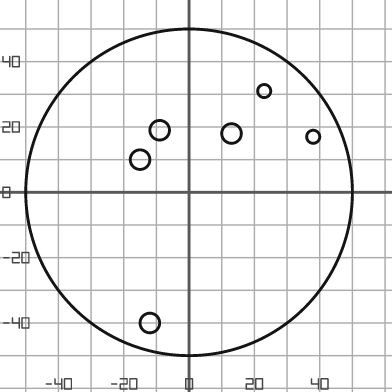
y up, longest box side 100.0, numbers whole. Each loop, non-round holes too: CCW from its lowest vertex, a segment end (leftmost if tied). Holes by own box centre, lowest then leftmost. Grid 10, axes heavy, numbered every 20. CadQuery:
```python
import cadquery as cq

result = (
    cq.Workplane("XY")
    .moveTo(0.0, 0.0)
    .circle(50.0)
    .moveTo(-12.0, -40.0)
    .circle(3.0)
    .moveTo(-15.0, 10.0)
    .circle(3.0)
    .moveTo(38.0, 17.0)
    .circle(2.0)
    .moveTo(13.0, 18.0)
    .circle(3.0)
    .moveTo(-9.0, 19.0)
    .circle(3.0)
    .moveTo(23.0, 31.0)
    .circle(2.0)
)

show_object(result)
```